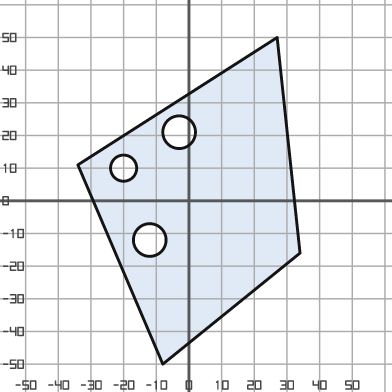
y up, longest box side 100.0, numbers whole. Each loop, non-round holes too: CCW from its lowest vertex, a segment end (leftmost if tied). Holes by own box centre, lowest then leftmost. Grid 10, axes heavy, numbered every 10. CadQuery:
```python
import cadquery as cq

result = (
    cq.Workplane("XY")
    .moveTo(-8.0, -50.0)
    .lineTo(34.0, -16.0)
    .lineTo(27.0, 50.0)
    .lineTo(-34.0, 11.0)
    .close()
    .moveTo(-12.0, -12.0)
    .circle(5.0)
    .moveTo(-20.0, 10.0)
    .circle(4.0)
    .moveTo(-3.0, 21.0)
    .circle(5.0)
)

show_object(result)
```